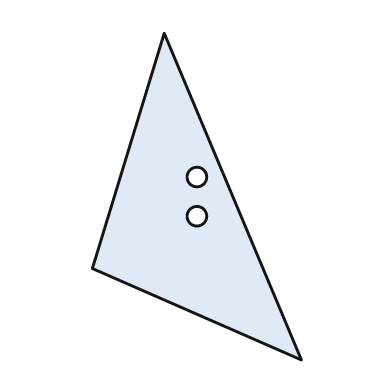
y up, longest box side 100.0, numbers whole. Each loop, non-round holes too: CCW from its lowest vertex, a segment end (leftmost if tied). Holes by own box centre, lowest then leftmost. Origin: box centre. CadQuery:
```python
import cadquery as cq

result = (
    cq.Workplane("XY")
    .moveTo(32.0, -50.0)
    .lineTo(-10.0, 50.0)
    .lineTo(-32.0, -22.0)
    .close()
    .moveTo(0.0, -6.0)
    .circle(3.0)
    .moveTo(0.0, 6.0)
    .circle(3.0)
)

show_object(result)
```